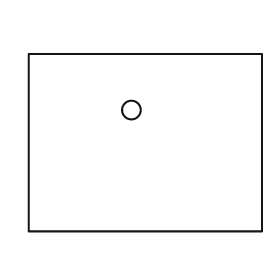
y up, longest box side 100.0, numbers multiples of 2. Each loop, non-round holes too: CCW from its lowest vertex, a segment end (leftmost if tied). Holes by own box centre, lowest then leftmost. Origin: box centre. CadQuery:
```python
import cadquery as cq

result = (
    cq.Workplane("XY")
    .moveTo(-50.0, -38.0)
    .lineTo(50.0, -38.0)
    .lineTo(50.0, 38.0)
    .lineTo(-50.0, 38.0)
    .close()
    .moveTo(-6.0, 14.0)
    .circle(4.0)
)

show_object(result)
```